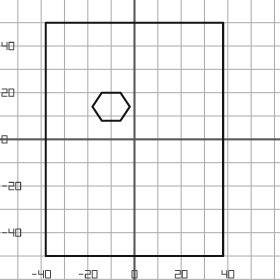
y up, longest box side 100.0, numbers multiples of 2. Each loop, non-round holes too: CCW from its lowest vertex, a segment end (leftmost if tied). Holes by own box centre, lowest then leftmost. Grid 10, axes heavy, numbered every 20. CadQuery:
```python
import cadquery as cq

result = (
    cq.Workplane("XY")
    .moveTo(-38.0, -50.0)
    .lineTo(38.0, -50.0)
    .lineTo(38.0, 50.0)
    .lineTo(-38.0, 50.0)
    .close()
    .moveTo(-14.0, 8.0)
    .lineTo(-6.0, 8.0)
    .lineTo(-2.0, 14.0)
    .lineTo(-6.0, 20.0)
    .lineTo(-14.0, 20.0)
    .lineTo(-18.0, 14.0)
    .close()
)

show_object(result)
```